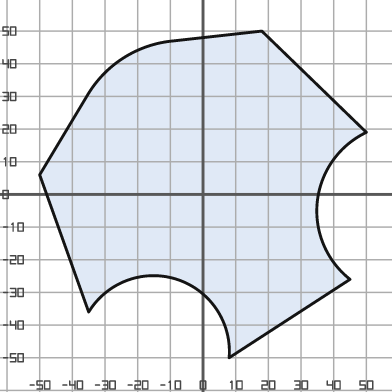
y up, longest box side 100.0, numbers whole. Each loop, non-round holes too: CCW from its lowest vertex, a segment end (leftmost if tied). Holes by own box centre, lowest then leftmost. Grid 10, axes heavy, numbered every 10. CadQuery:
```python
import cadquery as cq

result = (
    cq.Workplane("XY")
    .moveTo(8.0, -50.0)
    .lineTo(45.0, -26.0)
    .threePointArc((35.0, -2.0), (50.0, 19.0))
    .lineTo(18.0, 50.0)
    .lineTo(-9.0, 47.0)
    .threePointArc((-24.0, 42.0), (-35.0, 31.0))
    .lineTo(-50.0, 6.0)
    .lineTo(-35.0, -36.0)
    .threePointArc((-8.0, -26.0), (8.0, -50.0))
    .close()
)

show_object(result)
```